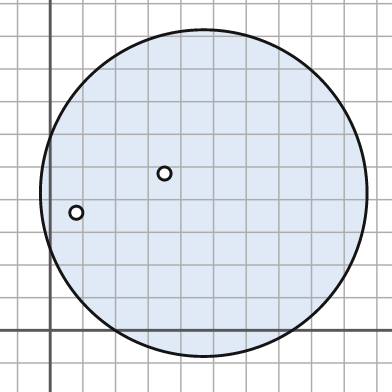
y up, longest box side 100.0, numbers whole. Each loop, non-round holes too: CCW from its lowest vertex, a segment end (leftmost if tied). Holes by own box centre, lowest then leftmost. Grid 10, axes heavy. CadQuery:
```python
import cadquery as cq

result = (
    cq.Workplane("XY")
    .moveTo(47.0, 42.0)
    .circle(50.0)
    .moveTo(8.0, 36.0)
    .circle(2.0)
    .moveTo(35.0, 48.0)
    .circle(2.0)
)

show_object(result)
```